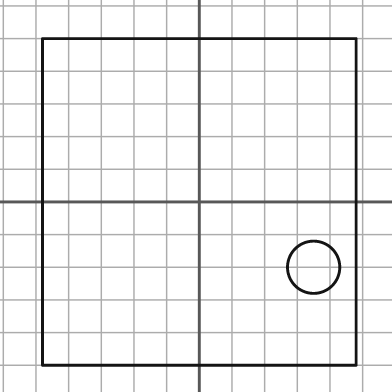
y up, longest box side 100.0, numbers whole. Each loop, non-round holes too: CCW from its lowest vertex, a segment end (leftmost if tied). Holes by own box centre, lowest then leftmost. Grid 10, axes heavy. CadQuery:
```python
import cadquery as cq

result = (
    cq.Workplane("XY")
    .moveTo(-48.0, -50.0)
    .lineTo(48.0, -50.0)
    .lineTo(48.0, 50.0)
    .lineTo(-48.0, 50.0)
    .close()
    .moveTo(35.0, -20.0)
    .circle(8.0)
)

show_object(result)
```